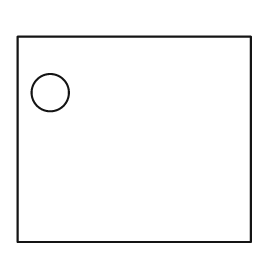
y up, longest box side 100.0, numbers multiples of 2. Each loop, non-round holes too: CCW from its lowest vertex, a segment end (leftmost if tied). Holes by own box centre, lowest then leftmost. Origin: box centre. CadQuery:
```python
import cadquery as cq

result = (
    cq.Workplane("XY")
    .moveTo(-50.0, -44.0)
    .lineTo(50.0, -44.0)
    .lineTo(50.0, 44.0)
    .lineTo(-50.0, 44.0)
    .close()
    .moveTo(-36.0, 20.0)
    .circle(8.0)
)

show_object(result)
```